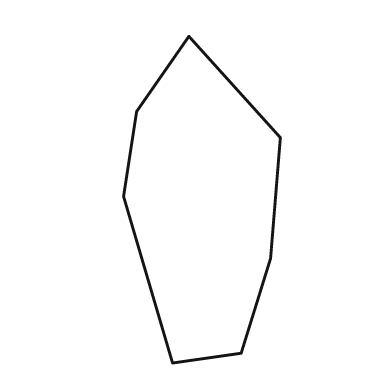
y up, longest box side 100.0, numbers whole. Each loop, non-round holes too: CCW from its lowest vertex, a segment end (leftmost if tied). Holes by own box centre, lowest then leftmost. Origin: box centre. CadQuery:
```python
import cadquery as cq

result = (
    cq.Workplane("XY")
    .moveTo(-9.0, -50.0)
    .lineTo(12.0, -47.0)
    .lineTo(21.0, -18.0)
    .lineTo(24.0, 19.0)
    .lineTo(-4.0, 50.0)
    .lineTo(-20.0, 27.0)
    .lineTo(-24.0, 1.0)
    .close()
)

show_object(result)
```